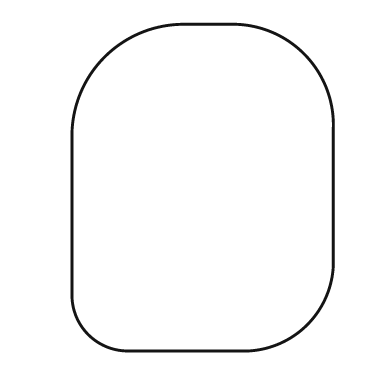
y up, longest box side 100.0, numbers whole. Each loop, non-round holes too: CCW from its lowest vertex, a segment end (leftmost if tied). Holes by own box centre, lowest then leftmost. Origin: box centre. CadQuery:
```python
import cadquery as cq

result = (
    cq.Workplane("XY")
    .moveTo(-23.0, -50.0)
    .lineTo(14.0, -50.0)
    .threePointArc((32.0, -42.0), (40.0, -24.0))
    .lineTo(40.0, 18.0)
    .threePointArc((31.0, 41.0), (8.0, 50.0))
    .lineTo(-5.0, 50.0)
    .threePointArc((-30.0, 40.0), (-40.0, 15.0))
    .lineTo(-40.0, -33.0)
    .threePointArc((-35.0, -45.0), (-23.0, -50.0))
    .close()
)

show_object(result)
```